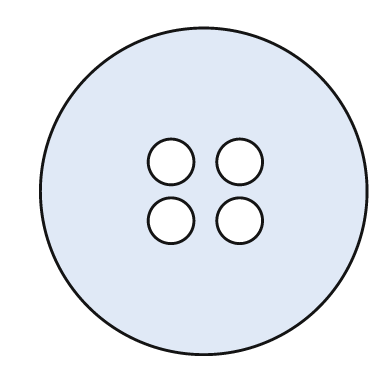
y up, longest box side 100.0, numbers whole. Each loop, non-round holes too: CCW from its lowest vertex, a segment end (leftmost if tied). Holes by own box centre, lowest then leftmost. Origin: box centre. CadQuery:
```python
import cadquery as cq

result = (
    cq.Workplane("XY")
    .moveTo(0.0, 0.0)
    .circle(50.0)
    .moveTo(-10.0, -9.0)
    .circle(7.0)
    .moveTo(11.0, -9.0)
    .circle(7.0)
    .moveTo(-10.0, 9.0)
    .circle(7.0)
    .moveTo(11.0, 9.0)
    .circle(7.0)
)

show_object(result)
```